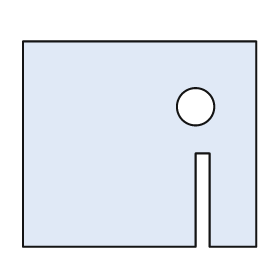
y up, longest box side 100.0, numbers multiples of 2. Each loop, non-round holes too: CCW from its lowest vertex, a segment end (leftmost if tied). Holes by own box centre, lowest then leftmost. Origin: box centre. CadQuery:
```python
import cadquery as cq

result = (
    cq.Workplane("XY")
    .moveTo(-50.0, -44.0)
    .lineTo(24.0, -44.0)
    .lineTo(24.0, -4.0)
    .lineTo(30.0, -4.0)
    .lineTo(30.0, -44.0)
    .lineTo(50.0, -44.0)
    .lineTo(50.0, 44.0)
    .lineTo(-50.0, 44.0)
    .close()
    .moveTo(24.0, 16.0)
    .circle(8.0)
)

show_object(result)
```